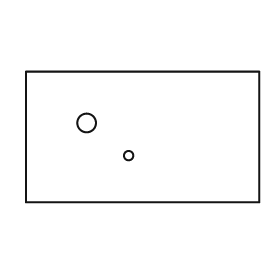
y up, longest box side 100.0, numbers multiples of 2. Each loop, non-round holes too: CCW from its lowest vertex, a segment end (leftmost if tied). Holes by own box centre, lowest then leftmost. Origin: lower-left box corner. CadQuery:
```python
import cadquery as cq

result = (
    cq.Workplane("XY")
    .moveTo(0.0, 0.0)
    .lineTo(100.0, 0.0)
    .lineTo(100.0, 56.0)
    .lineTo(0.0, 56.0)
    .close()
    .moveTo(44.0, 20.0)
    .circle(2.0)
    .moveTo(26.0, 34.0)
    .circle(4.0)
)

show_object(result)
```